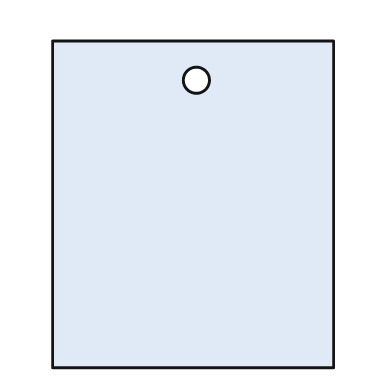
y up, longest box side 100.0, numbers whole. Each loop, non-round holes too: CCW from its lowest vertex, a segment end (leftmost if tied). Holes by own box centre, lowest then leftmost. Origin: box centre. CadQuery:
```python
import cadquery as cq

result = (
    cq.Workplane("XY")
    .moveTo(-43.0, -50.0)
    .lineTo(43.0, -50.0)
    .lineTo(43.0, 50.0)
    .lineTo(-43.0, 50.0)
    .close()
    .moveTo(1.0, 38.0)
    .circle(4.0)
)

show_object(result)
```